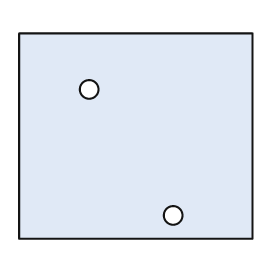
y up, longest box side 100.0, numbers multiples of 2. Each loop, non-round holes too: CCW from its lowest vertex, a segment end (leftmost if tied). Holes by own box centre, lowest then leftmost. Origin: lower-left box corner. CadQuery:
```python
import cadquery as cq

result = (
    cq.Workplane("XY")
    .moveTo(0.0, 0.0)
    .lineTo(100.0, 0.0)
    .lineTo(100.0, 88.0)
    .lineTo(0.0, 88.0)
    .close()
    .moveTo(66.0, 10.0)
    .circle(4.0)
    .moveTo(30.0, 64.0)
    .circle(4.0)
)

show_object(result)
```